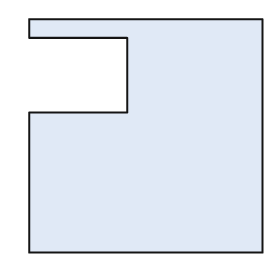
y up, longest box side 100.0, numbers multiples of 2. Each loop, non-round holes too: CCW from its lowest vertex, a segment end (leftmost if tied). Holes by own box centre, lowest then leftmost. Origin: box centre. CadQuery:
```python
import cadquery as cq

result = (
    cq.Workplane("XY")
    .moveTo(-50.0, -50.0)
    .lineTo(50.0, -50.0)
    .lineTo(50.0, 50.0)
    .lineTo(-50.0, 50.0)
    .lineTo(-50.0, 42.0)
    .lineTo(-8.0, 42.0)
    .lineTo(-8.0, 10.0)
    .lineTo(-50.0, 10.0)
    .close()
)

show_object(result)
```